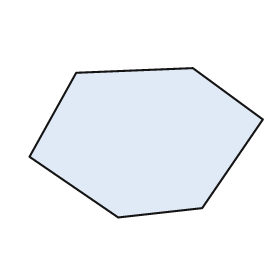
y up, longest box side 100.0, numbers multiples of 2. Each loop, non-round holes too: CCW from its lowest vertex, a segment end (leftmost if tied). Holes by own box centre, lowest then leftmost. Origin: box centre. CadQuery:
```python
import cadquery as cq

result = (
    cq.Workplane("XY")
    .moveTo(-12.0, -32.0)
    .lineTo(24.0, -28.0)
    .lineTo(50.0, 10.0)
    .lineTo(20.0, 32.0)
    .lineTo(-30.0, 30.0)
    .lineTo(-50.0, -6.0)
    .close()
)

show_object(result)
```